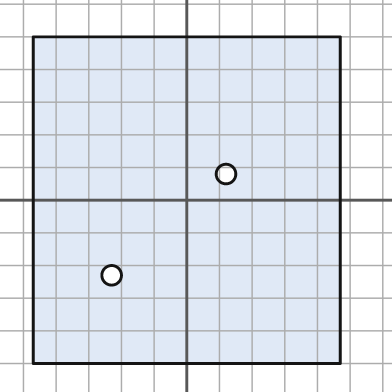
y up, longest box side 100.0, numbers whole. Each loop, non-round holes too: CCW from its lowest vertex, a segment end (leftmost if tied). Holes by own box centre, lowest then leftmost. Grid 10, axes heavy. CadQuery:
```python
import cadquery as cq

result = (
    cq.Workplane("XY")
    .moveTo(-47.0, -50.0)
    .lineTo(47.0, -50.0)
    .lineTo(47.0, 50.0)
    .lineTo(-47.0, 50.0)
    .close()
    .moveTo(-23.0, -23.0)
    .circle(3.0)
    .moveTo(12.0, 8.0)
    .circle(3.0)
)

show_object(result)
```